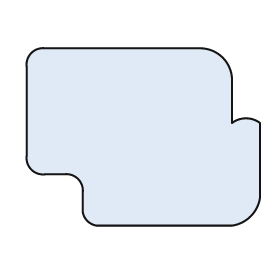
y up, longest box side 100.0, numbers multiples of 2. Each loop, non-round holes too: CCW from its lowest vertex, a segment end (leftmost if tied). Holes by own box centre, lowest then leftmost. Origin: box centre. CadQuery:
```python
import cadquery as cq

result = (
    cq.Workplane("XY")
    .moveTo(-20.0, -38.0)
    .lineTo(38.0, -38.0)
    .threePointArc((46.0, -34.0), (50.0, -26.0))
    .lineTo(50.0, 6.0)
    .threePointArc((44.0, 8.0), (38.0, 6.0))
    .lineTo(38.0, 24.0)
    .threePointArc((34.0, 34.0), (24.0, 38.0))
    .lineTo(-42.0, 38.0)
    .threePointArc((-48.0, 36.0), (-50.0, 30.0))
    .lineTo(-50.0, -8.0)
    .threePointArc((-48.0, -14.0), (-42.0, -16.0))
    .lineTo(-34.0, -16.0)
    .threePointArc((-28.0, -18.0), (-26.0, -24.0))
    .lineTo(-26.0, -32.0)
    .threePointArc((-24.0, -36.0), (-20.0, -38.0))
    .close()
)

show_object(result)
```